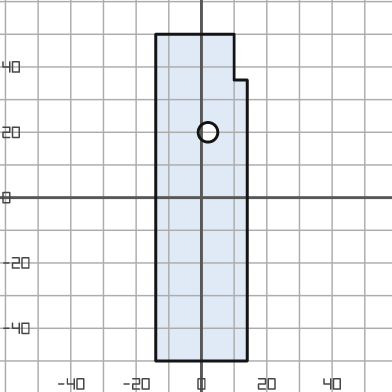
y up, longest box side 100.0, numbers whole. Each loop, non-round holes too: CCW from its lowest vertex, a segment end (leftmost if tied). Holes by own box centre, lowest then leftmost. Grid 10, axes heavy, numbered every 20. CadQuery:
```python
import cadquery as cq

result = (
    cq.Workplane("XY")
    .moveTo(-14.0, -50.0)
    .lineTo(14.0, -50.0)
    .lineTo(14.0, 36.0)
    .lineTo(10.0, 36.0)
    .lineTo(10.0, 50.0)
    .lineTo(-14.0, 50.0)
    .close()
    .moveTo(2.0, 20.0)
    .circle(3.0)
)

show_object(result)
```